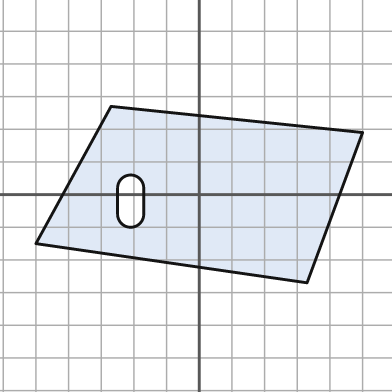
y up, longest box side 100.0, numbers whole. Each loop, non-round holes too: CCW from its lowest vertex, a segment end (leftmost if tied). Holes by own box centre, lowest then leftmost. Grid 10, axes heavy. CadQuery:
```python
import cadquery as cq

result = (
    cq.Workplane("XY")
    .moveTo(33.0, -27.0)
    .lineTo(50.0, 19.0)
    .lineTo(-27.0, 27.0)
    .lineTo(-50.0, -15.0)
    .close()
    .moveTo(-25.0, -6.0)
    .threePointArc((-21.0, -10.0), (-17.0, -6.0))
    .lineTo(-17.0, 2.0)
    .threePointArc((-21.0, 6.0), (-25.0, 2.0))
    .close()
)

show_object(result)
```